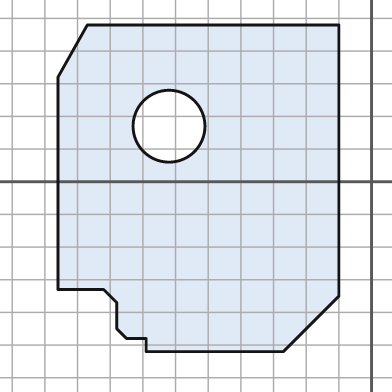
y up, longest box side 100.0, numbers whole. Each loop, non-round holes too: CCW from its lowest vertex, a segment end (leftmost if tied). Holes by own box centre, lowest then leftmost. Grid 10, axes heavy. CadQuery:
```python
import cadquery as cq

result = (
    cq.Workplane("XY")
    .moveTo(-69.0, -52.0)
    .lineTo(-27.0, -52.0)
    .lineTo(-10.0, -35.0)
    .lineTo(-10.0, 48.0)
    .lineTo(-87.0, 48.0)
    .lineTo(-96.0, 32.0)
    .lineTo(-96.0, -33.0)
    .lineTo(-82.0, -33.0)
    .lineTo(-78.0, -37.0)
    .lineTo(-78.0, -45.0)
    .lineTo(-75.0, -48.0)
    .lineTo(-69.0, -48.0)
    .close()
    .moveTo(-62.0, 17.0)
    .circle(11.0)
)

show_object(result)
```